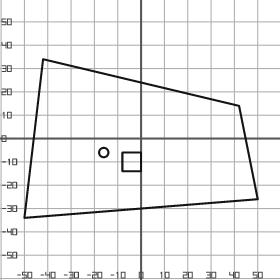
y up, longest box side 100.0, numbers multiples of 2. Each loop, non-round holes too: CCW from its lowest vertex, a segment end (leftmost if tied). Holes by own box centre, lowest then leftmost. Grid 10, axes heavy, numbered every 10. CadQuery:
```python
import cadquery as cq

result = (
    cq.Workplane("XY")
    .moveTo(-50.0, -34.0)
    .lineTo(50.0, -26.0)
    .lineTo(42.0, 14.0)
    .lineTo(-42.0, 34.0)
    .close()
    .moveTo(-8.0, -14.0)
    .lineTo(0.0, -14.0)
    .lineTo(0.0, -6.0)
    .lineTo(-8.0, -6.0)
    .close()
    .moveTo(-16.0, -6.0)
    .circle(2.0)
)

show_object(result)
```